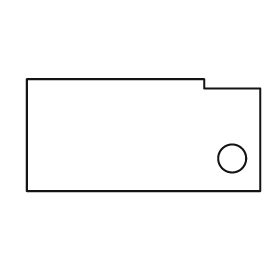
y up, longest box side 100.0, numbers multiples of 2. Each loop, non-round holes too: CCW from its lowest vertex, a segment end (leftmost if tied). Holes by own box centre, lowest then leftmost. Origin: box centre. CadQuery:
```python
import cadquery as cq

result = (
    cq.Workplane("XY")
    .moveTo(-50.0, -24.0)
    .lineTo(50.0, -24.0)
    .lineTo(50.0, 20.0)
    .lineTo(26.0, 20.0)
    .lineTo(26.0, 24.0)
    .lineTo(-50.0, 24.0)
    .close()
    .moveTo(38.0, -10.0)
    .circle(6.0)
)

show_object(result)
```